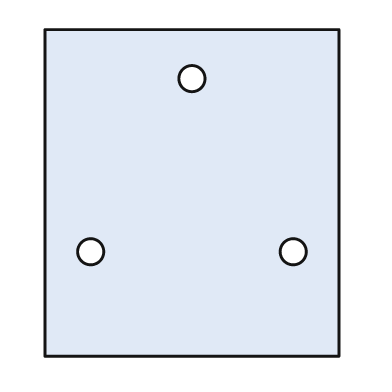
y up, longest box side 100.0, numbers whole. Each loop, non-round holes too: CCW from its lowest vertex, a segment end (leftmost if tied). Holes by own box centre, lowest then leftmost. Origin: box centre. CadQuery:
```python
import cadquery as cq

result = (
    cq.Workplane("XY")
    .moveTo(-45.0, -50.0)
    .lineTo(45.0, -50.0)
    .lineTo(45.0, 50.0)
    .lineTo(-45.0, 50.0)
    .close()
    .moveTo(-31.0, -18.0)
    .circle(4.0)
    .moveTo(31.0, -18.0)
    .circle(4.0)
    .moveTo(0.0, 35.0)
    .circle(4.0)
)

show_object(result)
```